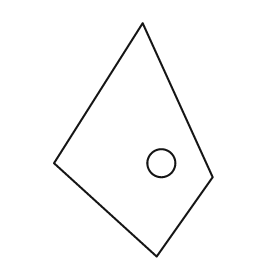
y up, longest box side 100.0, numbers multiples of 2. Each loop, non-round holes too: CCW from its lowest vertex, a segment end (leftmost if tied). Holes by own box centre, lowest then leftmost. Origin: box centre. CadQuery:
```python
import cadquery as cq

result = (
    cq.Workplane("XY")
    .moveTo(10.0, -50.0)
    .lineTo(34.0, -16.0)
    .lineTo(4.0, 50.0)
    .lineTo(-34.0, -10.0)
    .close()
    .moveTo(12.0, -10.0)
    .circle(6.0)
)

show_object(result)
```